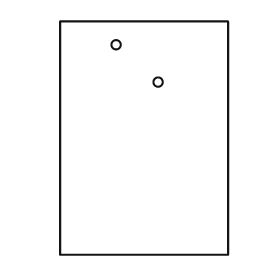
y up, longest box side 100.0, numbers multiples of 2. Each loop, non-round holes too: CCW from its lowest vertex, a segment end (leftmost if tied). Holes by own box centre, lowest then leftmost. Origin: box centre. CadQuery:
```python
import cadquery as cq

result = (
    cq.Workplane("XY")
    .moveTo(-36.0, -50.0)
    .lineTo(36.0, -50.0)
    .lineTo(36.0, 50.0)
    .lineTo(-36.0, 50.0)
    .close()
    .moveTo(6.0, 24.0)
    .circle(2.0)
    .moveTo(-12.0, 40.0)
    .circle(2.0)
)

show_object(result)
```